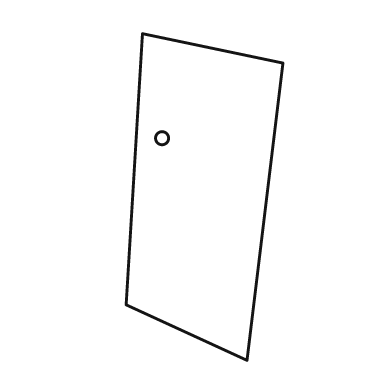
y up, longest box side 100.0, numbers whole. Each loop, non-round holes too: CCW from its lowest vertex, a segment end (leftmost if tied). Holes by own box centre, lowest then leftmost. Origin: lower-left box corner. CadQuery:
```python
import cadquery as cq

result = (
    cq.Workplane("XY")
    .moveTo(37.0, 0.0)
    .lineTo(48.0, 91.0)
    .lineTo(5.0, 100.0)
    .lineTo(0.0, 17.0)
    .close()
    .moveTo(11.0, 68.0)
    .circle(2.0)
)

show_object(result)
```